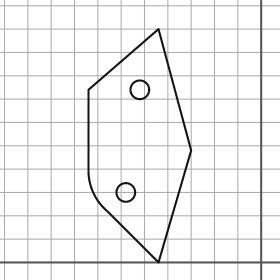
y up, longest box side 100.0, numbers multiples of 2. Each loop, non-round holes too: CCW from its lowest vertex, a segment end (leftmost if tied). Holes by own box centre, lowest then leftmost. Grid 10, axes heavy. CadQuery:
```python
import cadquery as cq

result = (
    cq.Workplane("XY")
    .moveTo(-44.0, 0.0)
    .lineTo(-30.0, 48.0)
    .lineTo(-44.0, 100.0)
    .lineTo(-74.0, 74.0)
    .lineTo(-74.0, 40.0)
    .threePointArc((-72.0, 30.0), (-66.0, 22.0))
    .close()
    .moveTo(-58.0, 30.0)
    .circle(4.0)
    .moveTo(-52.0, 74.0)
    .circle(4.0)
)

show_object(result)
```